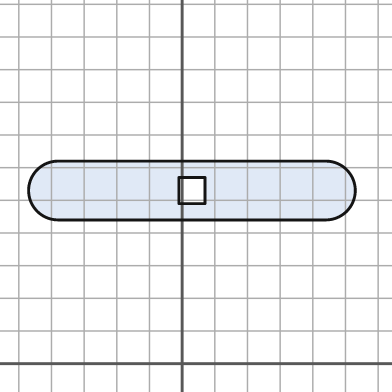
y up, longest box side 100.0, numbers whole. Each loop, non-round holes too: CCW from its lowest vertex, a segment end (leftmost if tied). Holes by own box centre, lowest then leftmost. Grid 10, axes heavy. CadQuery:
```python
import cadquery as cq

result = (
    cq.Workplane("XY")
    .moveTo(-38.0, 44.0)
    .lineTo(44.0, 44.0)
    .threePointArc((53.0, 53.0), (44.0, 62.0))
    .lineTo(-38.0, 62.0)
    .threePointArc((-47.0, 53.0), (-38.0, 44.0))
    .close()
    .moveTo(-1.0, 49.0)
    .lineTo(7.0, 49.0)
    .lineTo(7.0, 57.0)
    .lineTo(-1.0, 57.0)
    .close()
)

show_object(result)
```